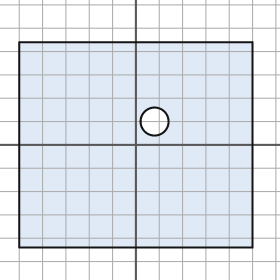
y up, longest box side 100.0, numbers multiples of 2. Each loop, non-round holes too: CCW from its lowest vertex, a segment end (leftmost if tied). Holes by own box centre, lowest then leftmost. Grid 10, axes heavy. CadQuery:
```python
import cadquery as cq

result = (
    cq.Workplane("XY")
    .moveTo(-50.0, -44.0)
    .lineTo(50.0, -44.0)
    .lineTo(50.0, 44.0)
    .lineTo(-50.0, 44.0)
    .close()
    .moveTo(8.0, 10.0)
    .circle(6.0)
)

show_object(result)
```